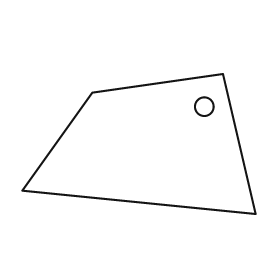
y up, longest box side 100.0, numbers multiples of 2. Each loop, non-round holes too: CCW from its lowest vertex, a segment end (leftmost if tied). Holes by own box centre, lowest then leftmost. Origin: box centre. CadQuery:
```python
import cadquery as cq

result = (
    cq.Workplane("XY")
    .moveTo(50.0, -30.0)
    .lineTo(36.0, 30.0)
    .lineTo(-20.0, 22.0)
    .lineTo(-50.0, -20.0)
    .close()
    .moveTo(28.0, 16.0)
    .circle(4.0)
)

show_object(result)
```